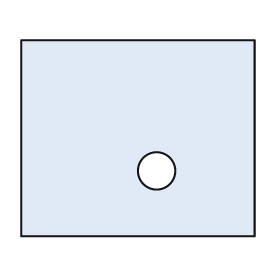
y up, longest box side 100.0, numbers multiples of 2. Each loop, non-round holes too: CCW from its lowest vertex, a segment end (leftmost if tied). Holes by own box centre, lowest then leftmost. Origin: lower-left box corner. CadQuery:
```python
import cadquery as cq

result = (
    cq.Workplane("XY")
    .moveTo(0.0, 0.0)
    .lineTo(100.0, 0.0)
    .lineTo(100.0, 84.0)
    .lineTo(0.0, 84.0)
    .close()
    .moveTo(58.0, 28.0)
    .circle(8.0)
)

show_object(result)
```